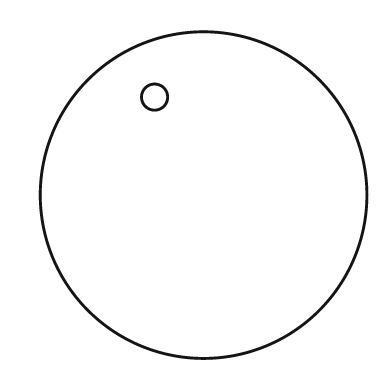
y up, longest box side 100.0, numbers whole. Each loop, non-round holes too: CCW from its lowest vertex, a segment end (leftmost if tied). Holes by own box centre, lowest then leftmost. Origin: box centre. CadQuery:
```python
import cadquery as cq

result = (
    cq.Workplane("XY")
    .moveTo(0.0, 0.0)
    .circle(50.0)
    .moveTo(-15.0, 30.0)
    .circle(4.0)
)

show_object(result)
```